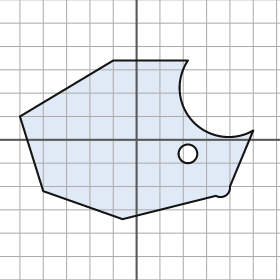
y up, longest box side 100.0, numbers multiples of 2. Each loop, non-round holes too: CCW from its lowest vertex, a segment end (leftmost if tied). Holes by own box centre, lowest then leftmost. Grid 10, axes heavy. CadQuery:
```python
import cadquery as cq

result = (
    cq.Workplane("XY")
    .moveTo(-6.0, -34.0)
    .lineTo(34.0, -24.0)
    .threePointArc((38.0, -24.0), (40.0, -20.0))
    .lineTo(50.0, 4.0)
    .threePointArc((24.0, 8.0), (22.0, 34.0))
    .lineTo(-10.0, 34.0)
    .lineTo(-50.0, 10.0)
    .lineTo(-40.0, -22.0)
    .close()
    .moveTo(22.0, -6.0)
    .circle(4.0)
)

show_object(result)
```